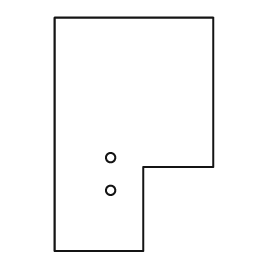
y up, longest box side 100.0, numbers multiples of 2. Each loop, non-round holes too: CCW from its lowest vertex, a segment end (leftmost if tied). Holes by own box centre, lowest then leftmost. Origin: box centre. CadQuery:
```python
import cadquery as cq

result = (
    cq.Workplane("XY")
    .moveTo(-34.0, -50.0)
    .lineTo(4.0, -50.0)
    .lineTo(4.0, -14.0)
    .lineTo(34.0, -14.0)
    .lineTo(34.0, 50.0)
    .lineTo(-34.0, 50.0)
    .close()
    .moveTo(-10.0, -24.0)
    .circle(2.0)
    .moveTo(-10.0, -10.0)
    .circle(2.0)
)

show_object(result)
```